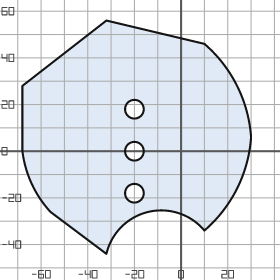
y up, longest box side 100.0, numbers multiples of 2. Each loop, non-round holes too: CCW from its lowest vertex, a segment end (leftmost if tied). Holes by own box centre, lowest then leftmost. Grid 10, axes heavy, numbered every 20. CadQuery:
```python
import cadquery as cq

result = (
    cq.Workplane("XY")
    .moveTo(-32.0, -44.0)
    .threePointArc((-14.0, -26.0), (10.0, -34.0))
    .threePointArc((24.0, -16.0), (30.0, 6.0))
    .threePointArc((24.0, 28.0), (10.0, 46.0))
    .lineTo(-32.0, 56.0)
    .lineTo(-68.0, 28.0)
    .lineTo(-68.0, 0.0)
    .threePointArc((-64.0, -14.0), (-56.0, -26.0))
    .close()
    .moveTo(-20.0, -18.0)
    .circle(4.0)
    .moveTo(-20.0, 0.0)
    .circle(4.0)
    .moveTo(-20.0, 18.0)
    .circle(4.0)
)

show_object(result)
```